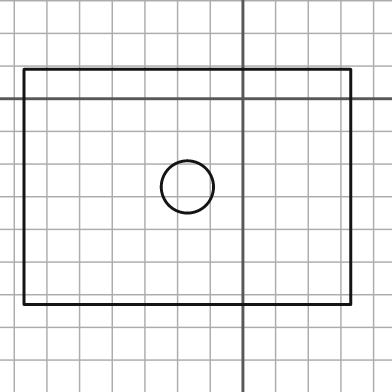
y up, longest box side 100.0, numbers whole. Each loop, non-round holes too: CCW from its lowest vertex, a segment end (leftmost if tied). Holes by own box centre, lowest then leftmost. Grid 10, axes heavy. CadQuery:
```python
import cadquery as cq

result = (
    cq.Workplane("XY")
    .moveTo(-67.0, -63.0)
    .lineTo(33.0, -63.0)
    .lineTo(33.0, 9.0)
    .lineTo(-67.0, 9.0)
    .close()
    .moveTo(-17.0, -27.0)
    .circle(8.0)
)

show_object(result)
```